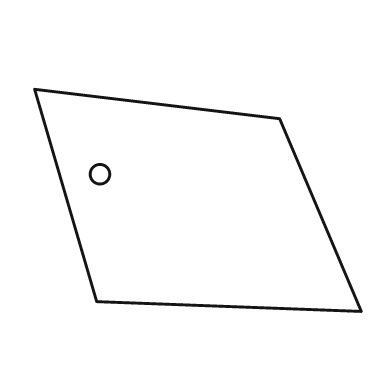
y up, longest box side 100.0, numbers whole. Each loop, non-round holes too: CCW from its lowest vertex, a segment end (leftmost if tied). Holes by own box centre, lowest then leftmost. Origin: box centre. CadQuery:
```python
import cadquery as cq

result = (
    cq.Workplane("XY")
    .moveTo(50.0, -34.0)
    .lineTo(25.0, 25.0)
    .lineTo(-50.0, 34.0)
    .lineTo(-31.0, -31.0)
    .close()
    .moveTo(-30.0, 8.0)
    .circle(3.0)
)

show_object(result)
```